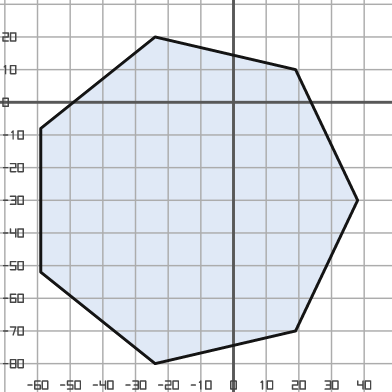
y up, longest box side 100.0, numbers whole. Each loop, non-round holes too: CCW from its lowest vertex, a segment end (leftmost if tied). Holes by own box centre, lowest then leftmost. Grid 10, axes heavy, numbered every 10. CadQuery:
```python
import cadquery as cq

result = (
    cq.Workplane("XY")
    .moveTo(-24.0, -80.0)
    .lineTo(19.0, -70.0)
    .lineTo(38.0, -30.0)
    .lineTo(19.0, 10.0)
    .lineTo(-24.0, 20.0)
    .lineTo(-59.0, -8.0)
    .lineTo(-59.0, -52.0)
    .close()
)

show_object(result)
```